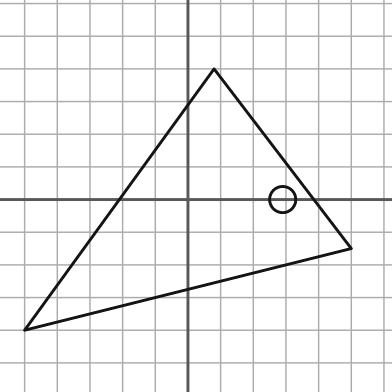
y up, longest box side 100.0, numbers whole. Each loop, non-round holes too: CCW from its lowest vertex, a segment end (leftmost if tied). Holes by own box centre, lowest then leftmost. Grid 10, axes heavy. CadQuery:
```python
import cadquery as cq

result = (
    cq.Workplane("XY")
    .moveTo(-50.0, -40.0)
    .lineTo(50.0, -15.0)
    .lineTo(8.0, 40.0)
    .close()
    .moveTo(29.0, 0.0)
    .circle(4.0)
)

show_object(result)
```